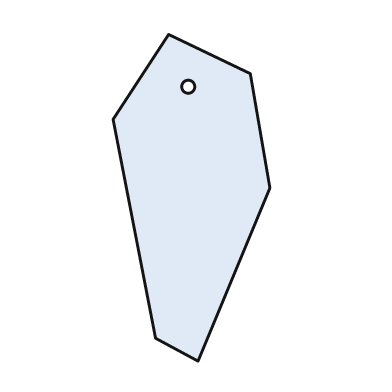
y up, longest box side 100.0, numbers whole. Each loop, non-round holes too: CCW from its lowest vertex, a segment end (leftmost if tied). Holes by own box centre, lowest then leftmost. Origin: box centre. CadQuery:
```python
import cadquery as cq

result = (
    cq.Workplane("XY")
    .moveTo(2.0, -50.0)
    .lineTo(24.0, 3.0)
    .lineTo(18.0, 38.0)
    .lineTo(-7.0, 50.0)
    .lineTo(-24.0, 24.0)
    .lineTo(-11.0, -43.0)
    .close()
    .moveTo(-1.0, 34.0)
    .circle(2.0)
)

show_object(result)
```